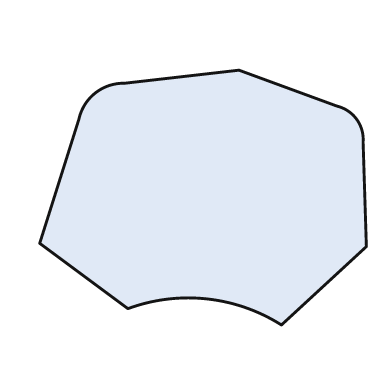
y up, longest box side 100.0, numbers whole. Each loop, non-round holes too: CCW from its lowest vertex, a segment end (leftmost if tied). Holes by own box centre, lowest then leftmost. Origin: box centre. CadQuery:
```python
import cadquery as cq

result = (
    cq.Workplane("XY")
    .moveTo(24.0, -39.0)
    .lineTo(50.0, -15.0)
    .lineTo(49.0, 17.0)
    .threePointArc((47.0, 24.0), (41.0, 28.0))
    .lineTo(11.0, 39.0)
    .lineTo(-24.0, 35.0)
    .threePointArc((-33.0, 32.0), (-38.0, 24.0))
    .lineTo(-50.0, -14.0)
    .lineTo(-23.0, -34.0)
    .threePointArc((1.0, -31.0), (24.0, -39.0))
    .close()
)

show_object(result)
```